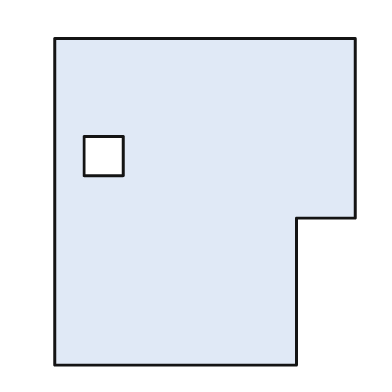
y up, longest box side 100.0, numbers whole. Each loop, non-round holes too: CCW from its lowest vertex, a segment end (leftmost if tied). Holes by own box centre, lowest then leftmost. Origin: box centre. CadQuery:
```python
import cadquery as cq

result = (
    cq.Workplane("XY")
    .moveTo(-46.0, -50.0)
    .lineTo(28.0, -50.0)
    .lineTo(28.0, -5.0)
    .lineTo(46.0, -5.0)
    .lineTo(46.0, 50.0)
    .lineTo(-46.0, 50.0)
    .close()
    .moveTo(-37.0, 8.0)
    .lineTo(-25.0, 8.0)
    .lineTo(-25.0, 20.0)
    .lineTo(-37.0, 20.0)
    .close()
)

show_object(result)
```